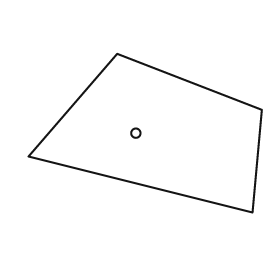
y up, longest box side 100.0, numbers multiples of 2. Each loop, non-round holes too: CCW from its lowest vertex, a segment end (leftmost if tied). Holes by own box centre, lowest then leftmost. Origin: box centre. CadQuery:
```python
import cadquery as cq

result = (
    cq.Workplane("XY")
    .moveTo(46.0, -34.0)
    .lineTo(50.0, 10.0)
    .lineTo(-12.0, 34.0)
    .lineTo(-50.0, -10.0)
    .close()
    .moveTo(-4.0, 0.0)
    .circle(2.0)
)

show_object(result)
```